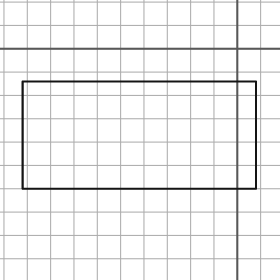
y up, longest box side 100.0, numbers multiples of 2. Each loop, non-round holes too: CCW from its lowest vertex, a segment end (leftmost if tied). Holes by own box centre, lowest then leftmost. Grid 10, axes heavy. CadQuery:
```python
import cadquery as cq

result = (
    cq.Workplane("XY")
    .moveTo(-92.0, -60.0)
    .lineTo(8.0, -60.0)
    .lineTo(8.0, -14.0)
    .lineTo(-92.0, -14.0)
    .close()
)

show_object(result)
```